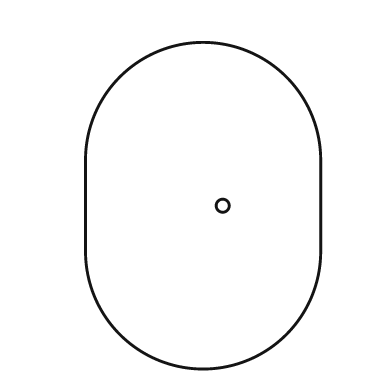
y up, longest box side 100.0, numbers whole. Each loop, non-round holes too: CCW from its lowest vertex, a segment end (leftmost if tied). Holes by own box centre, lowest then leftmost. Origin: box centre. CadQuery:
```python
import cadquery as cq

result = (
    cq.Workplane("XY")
    .moveTo(-36.0, -14.0)
    .threePointArc((0.0, -50.0), (36.0, -14.0))
    .lineTo(36.0, 14.0)
    .threePointArc((0.0, 50.0), (-36.0, 14.0))
    .close()
    .moveTo(6.0, 0.0)
    .circle(2.0)
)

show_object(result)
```